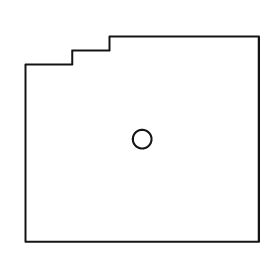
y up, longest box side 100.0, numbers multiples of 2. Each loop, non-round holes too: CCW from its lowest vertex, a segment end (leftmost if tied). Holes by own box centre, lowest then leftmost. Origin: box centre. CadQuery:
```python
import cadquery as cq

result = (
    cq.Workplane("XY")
    .moveTo(-50.0, -44.0)
    .lineTo(50.0, -44.0)
    .lineTo(50.0, 44.0)
    .lineTo(-14.0, 44.0)
    .lineTo(-14.0, 38.0)
    .lineTo(-30.0, 38.0)
    .lineTo(-30.0, 32.0)
    .lineTo(-50.0, 32.0)
    .close()
    .moveTo(0.0, 0.0)
    .circle(4.0)
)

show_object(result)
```